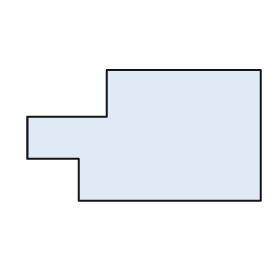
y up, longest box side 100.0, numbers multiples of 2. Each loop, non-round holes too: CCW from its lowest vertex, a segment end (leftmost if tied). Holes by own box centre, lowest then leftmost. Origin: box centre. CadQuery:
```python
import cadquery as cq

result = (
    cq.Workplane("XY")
    .moveTo(-28.0, -28.0)
    .lineTo(50.0, -28.0)
    .lineTo(50.0, 28.0)
    .lineTo(-16.0, 28.0)
    .lineTo(-16.0, 8.0)
    .lineTo(-50.0, 8.0)
    .lineTo(-50.0, -10.0)
    .lineTo(-28.0, -10.0)
    .close()
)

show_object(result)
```